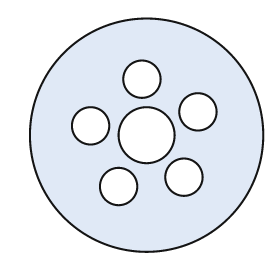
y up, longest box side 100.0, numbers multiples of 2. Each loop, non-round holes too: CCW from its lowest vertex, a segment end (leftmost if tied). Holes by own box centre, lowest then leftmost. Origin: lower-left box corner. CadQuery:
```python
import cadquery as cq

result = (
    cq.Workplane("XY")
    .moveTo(50.0, 50.0)
    .circle(50.0)
    .moveTo(38.0, 28.0)
    .circle(8.0)
    .moveTo(66.0, 32.0)
    .circle(8.0)
    .moveTo(50.0, 50.0)
    .circle(12.0)
    .moveTo(26.0, 54.0)
    .circle(8.0)
    .moveTo(72.0, 60.0)
    .circle(8.0)
    .moveTo(48.0, 74.0)
    .circle(8.0)
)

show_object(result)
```